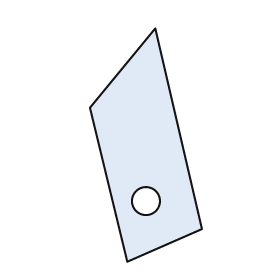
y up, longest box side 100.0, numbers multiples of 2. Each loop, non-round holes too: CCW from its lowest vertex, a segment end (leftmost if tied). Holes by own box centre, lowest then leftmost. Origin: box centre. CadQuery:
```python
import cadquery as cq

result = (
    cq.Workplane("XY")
    .moveTo(-8.0, -50.0)
    .lineTo(24.0, -36.0)
    .lineTo(4.0, 50.0)
    .lineTo(-24.0, 16.0)
    .close()
    .moveTo(0.0, -24.0)
    .circle(6.0)
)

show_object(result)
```